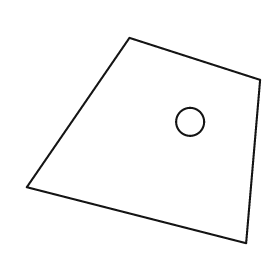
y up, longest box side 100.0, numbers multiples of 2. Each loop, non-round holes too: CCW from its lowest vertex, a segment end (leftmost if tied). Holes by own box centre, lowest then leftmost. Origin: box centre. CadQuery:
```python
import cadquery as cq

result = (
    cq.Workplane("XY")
    .moveTo(44.0, -44.0)
    .lineTo(50.0, 26.0)
    .lineTo(-6.0, 44.0)
    .lineTo(-50.0, -20.0)
    .close()
    .moveTo(20.0, 8.0)
    .circle(6.0)
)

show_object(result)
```